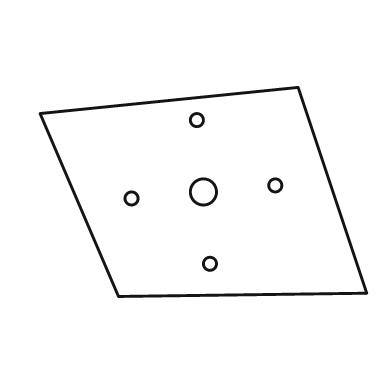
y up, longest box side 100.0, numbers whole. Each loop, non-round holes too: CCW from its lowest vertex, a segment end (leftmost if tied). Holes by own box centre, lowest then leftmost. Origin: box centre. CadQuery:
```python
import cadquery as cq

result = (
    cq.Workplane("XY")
    .moveTo(-26.0, -32.0)
    .lineTo(50.0, -31.0)
    .lineTo(29.0, 32.0)
    .lineTo(-50.0, 24.0)
    .close()
    .moveTo(2.0, -22.0)
    .circle(2.0)
    .moveTo(-22.0, -2.0)
    .circle(2.0)
    .moveTo(0.0, 0.0)
    .circle(4.0)
    .moveTo(22.0, 2.0)
    .circle(2.0)
    .moveTo(-2.0, 22.0)
    .circle(2.0)
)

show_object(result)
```